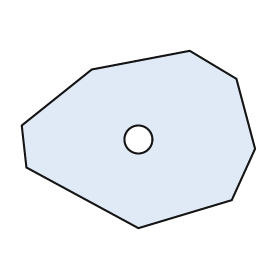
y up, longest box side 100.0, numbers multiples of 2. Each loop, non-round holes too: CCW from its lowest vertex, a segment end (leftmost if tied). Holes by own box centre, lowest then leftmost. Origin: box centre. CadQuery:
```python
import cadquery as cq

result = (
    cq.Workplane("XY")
    .moveTo(0.0, -38.0)
    .lineTo(40.0, -26.0)
    .lineTo(50.0, -4.0)
    .lineTo(42.0, 26.0)
    .lineTo(22.0, 38.0)
    .lineTo(-20.0, 30.0)
    .lineTo(-50.0, 6.0)
    .lineTo(-48.0, -12.0)
    .close()
    .moveTo(0.0, 0.0)
    .circle(6.0)
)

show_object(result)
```